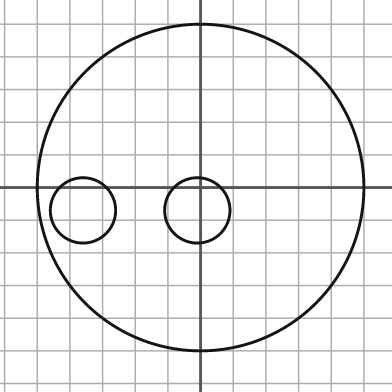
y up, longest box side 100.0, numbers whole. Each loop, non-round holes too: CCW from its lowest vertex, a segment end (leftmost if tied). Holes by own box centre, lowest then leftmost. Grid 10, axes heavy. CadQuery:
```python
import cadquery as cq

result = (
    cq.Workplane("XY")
    .moveTo(0.0, 0.0)
    .circle(50.0)
    .moveTo(-36.0, -7.0)
    .circle(10.0)
    .moveTo(-1.0, -7.0)
    .circle(10.0)
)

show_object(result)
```